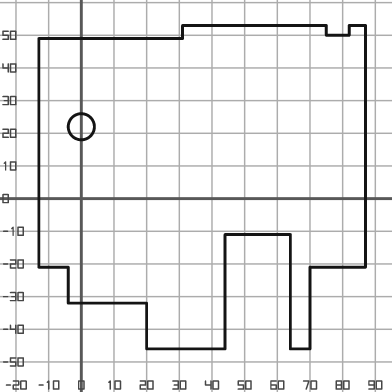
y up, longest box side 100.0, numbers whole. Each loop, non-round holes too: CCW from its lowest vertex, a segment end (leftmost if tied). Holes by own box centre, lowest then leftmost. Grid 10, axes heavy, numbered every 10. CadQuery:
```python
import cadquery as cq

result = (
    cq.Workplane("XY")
    .moveTo(20.0, -46.0)
    .lineTo(44.0, -46.0)
    .lineTo(44.0, -11.0)
    .lineTo(64.0, -11.0)
    .lineTo(64.0, -46.0)
    .lineTo(70.0, -46.0)
    .lineTo(70.0, -21.0)
    .lineTo(87.0, -21.0)
    .lineTo(87.0, 53.0)
    .lineTo(82.0, 53.0)
    .lineTo(82.0, 50.0)
    .lineTo(75.0, 50.0)
    .lineTo(75.0, 53.0)
    .lineTo(31.0, 53.0)
    .lineTo(31.0, 49.0)
    .lineTo(-13.0, 49.0)
    .lineTo(-13.0, -21.0)
    .lineTo(-4.0, -21.0)
    .lineTo(-4.0, -32.0)
    .lineTo(20.0, -32.0)
    .close()
    .moveTo(0.0, 22.0)
    .circle(4.0)
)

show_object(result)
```